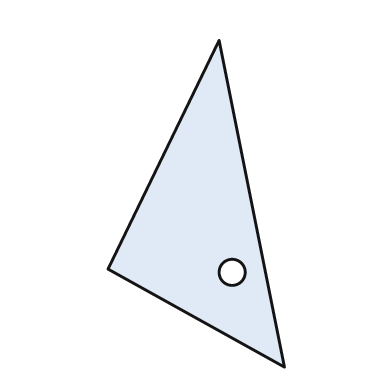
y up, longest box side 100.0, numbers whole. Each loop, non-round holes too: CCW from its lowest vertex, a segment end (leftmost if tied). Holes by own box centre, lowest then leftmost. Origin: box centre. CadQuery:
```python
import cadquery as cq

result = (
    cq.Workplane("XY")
    .moveTo(27.0, -50.0)
    .lineTo(7.0, 50.0)
    .lineTo(-27.0, -20.0)
    .close()
    .moveTo(11.0, -21.0)
    .circle(4.0)
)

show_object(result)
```